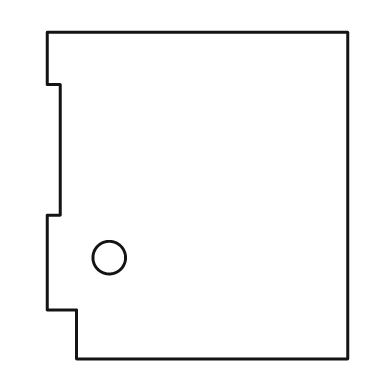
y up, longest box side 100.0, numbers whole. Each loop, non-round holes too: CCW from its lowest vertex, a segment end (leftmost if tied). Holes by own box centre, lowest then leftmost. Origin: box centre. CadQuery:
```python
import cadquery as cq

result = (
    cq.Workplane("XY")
    .moveTo(-37.0, -50.0)
    .lineTo(46.0, -50.0)
    .lineTo(46.0, 50.0)
    .lineTo(-46.0, 50.0)
    .lineTo(-46.0, 34.0)
    .lineTo(-42.0, 34.0)
    .lineTo(-42.0, -6.0)
    .lineTo(-46.0, -6.0)
    .lineTo(-46.0, -35.0)
    .lineTo(-37.0, -35.0)
    .close()
    .moveTo(-27.0, -19.0)
    .circle(5.0)
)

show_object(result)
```